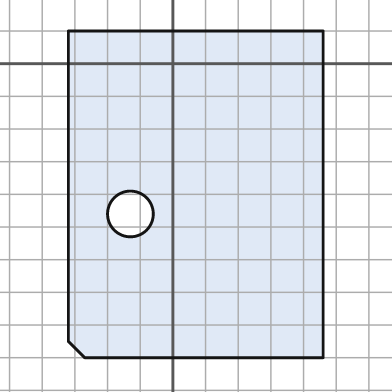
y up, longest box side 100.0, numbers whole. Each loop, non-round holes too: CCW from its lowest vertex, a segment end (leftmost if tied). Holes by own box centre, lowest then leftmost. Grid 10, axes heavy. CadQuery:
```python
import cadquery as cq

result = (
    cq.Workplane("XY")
    .moveTo(-27.0, -90.0)
    .lineTo(46.0, -90.0)
    .lineTo(46.0, 10.0)
    .lineTo(-32.0, 10.0)
    .lineTo(-32.0, -85.0)
    .close()
    .moveTo(-13.0, -46.0)
    .circle(7.0)
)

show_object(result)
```